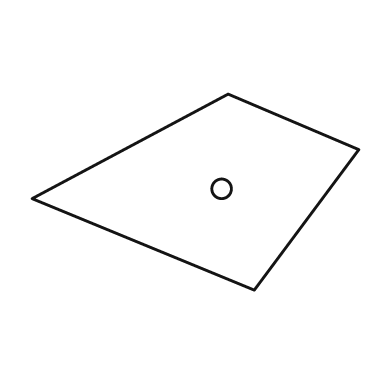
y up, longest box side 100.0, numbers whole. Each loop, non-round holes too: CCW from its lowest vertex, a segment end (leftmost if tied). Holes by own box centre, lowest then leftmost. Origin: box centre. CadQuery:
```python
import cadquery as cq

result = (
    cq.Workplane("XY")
    .moveTo(18.0, -30.0)
    .lineTo(50.0, 13.0)
    .lineTo(10.0, 30.0)
    .lineTo(-50.0, -2.0)
    .close()
    .moveTo(8.0, 1.0)
    .circle(3.0)
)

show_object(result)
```